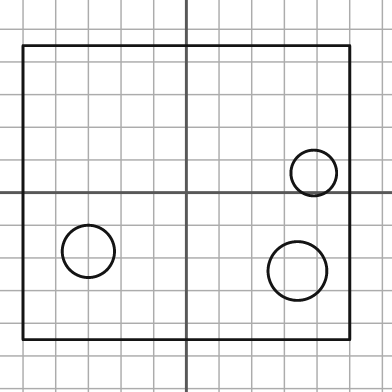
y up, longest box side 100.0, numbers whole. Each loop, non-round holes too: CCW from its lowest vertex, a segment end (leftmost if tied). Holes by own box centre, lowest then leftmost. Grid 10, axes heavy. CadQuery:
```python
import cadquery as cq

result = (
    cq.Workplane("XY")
    .moveTo(-50.0, -45.0)
    .lineTo(50.0, -45.0)
    .lineTo(50.0, 45.0)
    .lineTo(-50.0, 45.0)
    .close()
    .moveTo(34.0, -24.0)
    .circle(9.0)
    .moveTo(-30.0, -18.0)
    .circle(8.0)
    .moveTo(39.0, 6.0)
    .circle(7.0)
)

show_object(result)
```